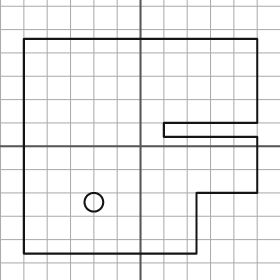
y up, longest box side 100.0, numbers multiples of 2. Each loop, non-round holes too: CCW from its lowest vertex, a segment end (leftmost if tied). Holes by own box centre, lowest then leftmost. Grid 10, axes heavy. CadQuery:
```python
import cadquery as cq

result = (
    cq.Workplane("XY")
    .moveTo(-50.0, -46.0)
    .lineTo(24.0, -46.0)
    .lineTo(24.0, -20.0)
    .lineTo(50.0, -20.0)
    .lineTo(50.0, 4.0)
    .lineTo(10.0, 4.0)
    .lineTo(10.0, 10.0)
    .lineTo(50.0, 10.0)
    .lineTo(50.0, 46.0)
    .lineTo(-50.0, 46.0)
    .close()
    .moveTo(-20.0, -24.0)
    .circle(4.0)
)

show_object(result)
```